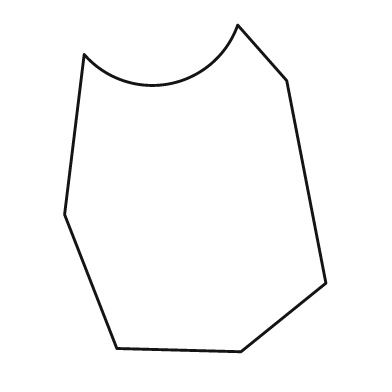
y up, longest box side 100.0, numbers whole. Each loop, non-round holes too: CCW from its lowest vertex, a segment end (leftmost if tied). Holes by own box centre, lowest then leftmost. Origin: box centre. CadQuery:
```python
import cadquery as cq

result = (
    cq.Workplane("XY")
    .moveTo(14.0, -50.0)
    .lineTo(40.0, -29.0)
    .lineTo(28.0, 33.0)
    .lineTo(13.0, 50.0)
    .threePointArc((-8.0, 32.0), (-34.0, 41.0))
    .lineTo(-40.0, -8.0)
    .lineTo(-24.0, -49.0)
    .close()
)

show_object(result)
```